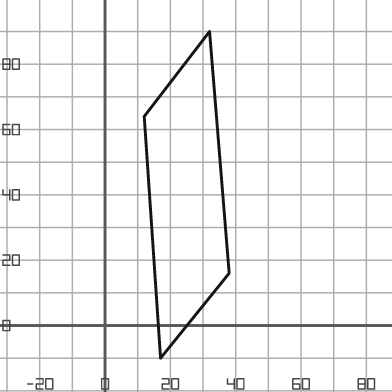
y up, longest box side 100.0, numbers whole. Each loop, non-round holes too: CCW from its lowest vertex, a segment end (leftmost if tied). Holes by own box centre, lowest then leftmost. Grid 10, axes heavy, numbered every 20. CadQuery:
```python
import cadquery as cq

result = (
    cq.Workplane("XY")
    .moveTo(17.0, -10.0)
    .lineTo(38.0, 16.0)
    .lineTo(32.0, 90.0)
    .lineTo(12.0, 64.0)
    .close()
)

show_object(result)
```